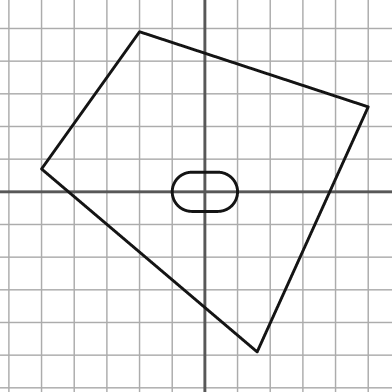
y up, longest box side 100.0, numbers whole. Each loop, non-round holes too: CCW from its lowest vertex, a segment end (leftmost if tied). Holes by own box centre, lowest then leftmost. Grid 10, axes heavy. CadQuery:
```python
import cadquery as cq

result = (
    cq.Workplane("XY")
    .moveTo(16.0, -49.0)
    .lineTo(50.0, 26.0)
    .lineTo(-20.0, 49.0)
    .lineTo(-50.0, 7.0)
    .close()
    .moveTo(-4.0, -6.0)
    .lineTo(4.0, -6.0)
    .threePointArc((10.0, 0.0), (4.0, 6.0))
    .lineTo(-4.0, 6.0)
    .threePointArc((-10.0, 0.0), (-4.0, -6.0))
    .close()
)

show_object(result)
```